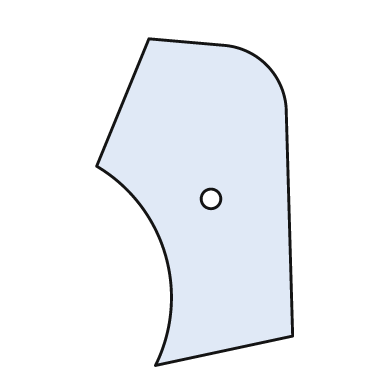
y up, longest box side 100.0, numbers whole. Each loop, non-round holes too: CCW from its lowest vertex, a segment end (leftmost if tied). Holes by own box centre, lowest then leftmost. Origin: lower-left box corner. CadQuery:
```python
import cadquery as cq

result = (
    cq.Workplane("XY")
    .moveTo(18.0, 0.0)
    .lineTo(60.0, 9.0)
    .lineTo(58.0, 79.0)
    .threePointArc((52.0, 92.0), (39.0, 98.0))
    .lineTo(16.0, 100.0)
    .lineTo(0.0, 61.0)
    .threePointArc((21.0, 34.0), (18.0, 0.0))
    .close()
    .moveTo(35.0, 51.0)
    .circle(3.0)
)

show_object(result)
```